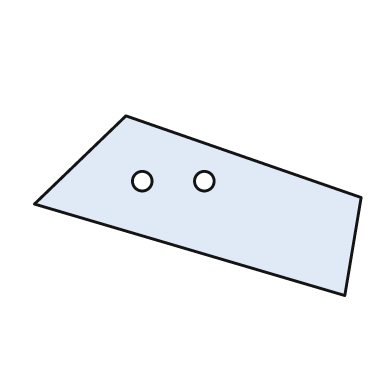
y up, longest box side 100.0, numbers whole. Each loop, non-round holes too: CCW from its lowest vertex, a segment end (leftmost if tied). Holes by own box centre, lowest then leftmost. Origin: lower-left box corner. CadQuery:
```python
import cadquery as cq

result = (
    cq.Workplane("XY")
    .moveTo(95.0, 0.0)
    .lineTo(100.0, 30.0)
    .lineTo(28.0, 55.0)
    .lineTo(0.0, 28.0)
    .close()
    .moveTo(33.0, 35.0)
    .circle(3.0)
    .moveTo(52.0, 35.0)
    .circle(3.0)
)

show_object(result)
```